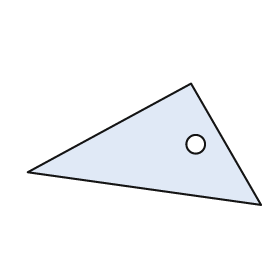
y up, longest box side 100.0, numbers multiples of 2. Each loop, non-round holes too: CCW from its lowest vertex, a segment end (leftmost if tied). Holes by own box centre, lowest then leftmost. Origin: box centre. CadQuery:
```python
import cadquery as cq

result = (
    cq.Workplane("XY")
    .moveTo(50.0, -26.0)
    .lineTo(20.0, 26.0)
    .lineTo(-50.0, -12.0)
    .close()
    .moveTo(22.0, 0.0)
    .circle(4.0)
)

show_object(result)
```